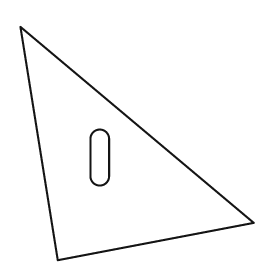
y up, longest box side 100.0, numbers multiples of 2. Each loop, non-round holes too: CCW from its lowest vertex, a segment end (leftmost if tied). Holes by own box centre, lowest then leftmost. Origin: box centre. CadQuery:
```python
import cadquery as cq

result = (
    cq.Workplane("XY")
    .moveTo(-34.0, -50.0)
    .lineTo(50.0, -34.0)
    .lineTo(-50.0, 50.0)
    .close()
    .moveTo(-20.0, -14.0)
    .threePointArc((-16.0, -18.0), (-12.0, -14.0))
    .lineTo(-12.0, 2.0)
    .threePointArc((-16.0, 6.0), (-20.0, 2.0))
    .close()
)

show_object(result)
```